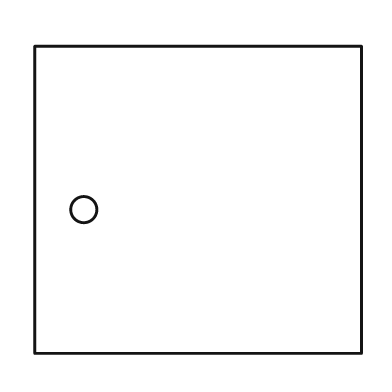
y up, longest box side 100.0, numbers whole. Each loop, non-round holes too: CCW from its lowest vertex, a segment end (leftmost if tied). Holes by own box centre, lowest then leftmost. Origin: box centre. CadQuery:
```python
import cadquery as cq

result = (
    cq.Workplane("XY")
    .moveTo(-50.0, -47.0)
    .lineTo(50.0, -47.0)
    .lineTo(50.0, 47.0)
    .lineTo(-50.0, 47.0)
    .close()
    .moveTo(-35.0, -3.0)
    .circle(4.0)
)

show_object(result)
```